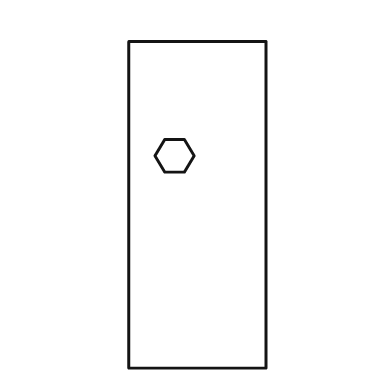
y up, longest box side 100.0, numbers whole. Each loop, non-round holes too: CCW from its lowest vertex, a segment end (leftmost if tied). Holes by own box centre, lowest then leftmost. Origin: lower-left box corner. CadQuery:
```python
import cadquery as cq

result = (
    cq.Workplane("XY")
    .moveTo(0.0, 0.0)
    .lineTo(42.0, 0.0)
    .lineTo(42.0, 100.0)
    .lineTo(0.0, 100.0)
    .close()
    .moveTo(11.0, 60.0)
    .lineTo(17.0, 60.0)
    .lineTo(20.0, 65.0)
    .lineTo(17.0, 70.0)
    .lineTo(11.0, 70.0)
    .lineTo(8.0, 65.0)
    .close()
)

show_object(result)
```